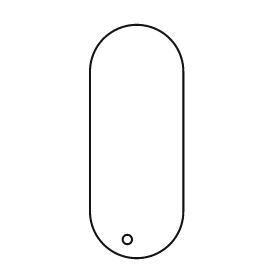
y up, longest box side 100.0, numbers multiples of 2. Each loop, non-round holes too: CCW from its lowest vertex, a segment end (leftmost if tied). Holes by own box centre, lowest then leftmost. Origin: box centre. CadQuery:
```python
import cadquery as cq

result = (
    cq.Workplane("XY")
    .moveTo(-20.0, -30.0)
    .threePointArc((0.0, -50.0), (20.0, -30.0))
    .lineTo(20.0, 30.0)
    .threePointArc((0.0, 50.0), (-20.0, 30.0))
    .close()
    .moveTo(-4.0, -42.0)
    .circle(2.0)
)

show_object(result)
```